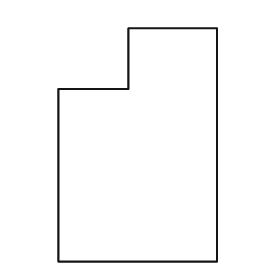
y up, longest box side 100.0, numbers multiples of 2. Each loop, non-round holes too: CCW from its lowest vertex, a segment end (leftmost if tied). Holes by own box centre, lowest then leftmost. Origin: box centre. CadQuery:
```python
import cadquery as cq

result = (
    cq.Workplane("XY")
    .moveTo(-34.0, -50.0)
    .lineTo(34.0, -50.0)
    .lineTo(34.0, 50.0)
    .lineTo(-4.0, 50.0)
    .lineTo(-4.0, 24.0)
    .lineTo(-34.0, 24.0)
    .close()
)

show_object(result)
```